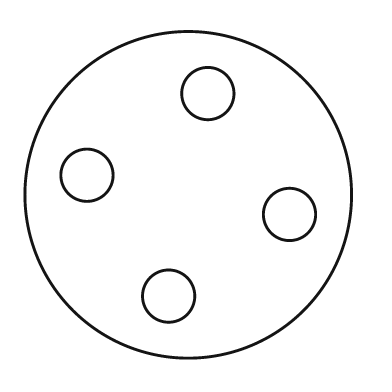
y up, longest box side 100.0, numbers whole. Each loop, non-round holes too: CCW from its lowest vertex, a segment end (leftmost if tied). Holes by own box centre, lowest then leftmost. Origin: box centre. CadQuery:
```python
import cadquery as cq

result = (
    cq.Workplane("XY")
    .moveTo(0.0, 0.0)
    .circle(50.0)
    .moveTo(-6.0, -31.0)
    .circle(8.0)
    .moveTo(31.0, -6.0)
    .circle(8.0)
    .moveTo(-31.0, 6.0)
    .circle(8.0)
    .moveTo(6.0, 31.0)
    .circle(8.0)
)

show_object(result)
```